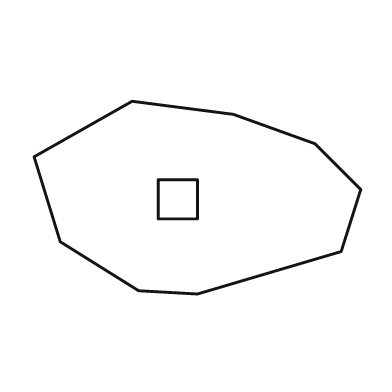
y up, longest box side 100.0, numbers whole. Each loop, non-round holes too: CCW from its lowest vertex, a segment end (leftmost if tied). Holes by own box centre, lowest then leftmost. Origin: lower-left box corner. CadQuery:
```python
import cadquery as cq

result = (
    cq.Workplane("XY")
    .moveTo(50.0, 0.0)
    .lineTo(94.0, 13.0)
    .lineTo(100.0, 32.0)
    .lineTo(86.0, 46.0)
    .lineTo(61.0, 55.0)
    .lineTo(30.0, 59.0)
    .lineTo(0.0, 42.0)
    .lineTo(8.0, 16.0)
    .lineTo(32.0, 1.0)
    .close()
    .moveTo(38.0, 23.0)
    .lineTo(50.0, 23.0)
    .lineTo(50.0, 35.0)
    .lineTo(38.0, 35.0)
    .close()
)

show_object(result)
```